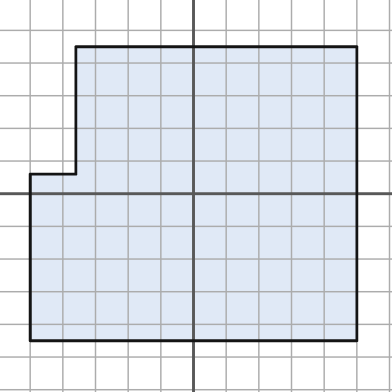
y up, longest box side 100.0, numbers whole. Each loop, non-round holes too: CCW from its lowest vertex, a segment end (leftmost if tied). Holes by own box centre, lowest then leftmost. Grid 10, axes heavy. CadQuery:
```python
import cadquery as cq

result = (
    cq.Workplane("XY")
    .moveTo(-50.0, -45.0)
    .lineTo(50.0, -45.0)
    .lineTo(50.0, 45.0)
    .lineTo(-36.0, 45.0)
    .lineTo(-36.0, 6.0)
    .lineTo(-50.0, 6.0)
    .close()
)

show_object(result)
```